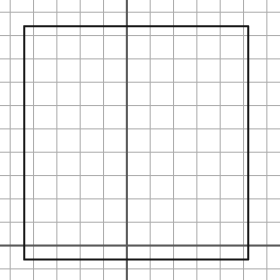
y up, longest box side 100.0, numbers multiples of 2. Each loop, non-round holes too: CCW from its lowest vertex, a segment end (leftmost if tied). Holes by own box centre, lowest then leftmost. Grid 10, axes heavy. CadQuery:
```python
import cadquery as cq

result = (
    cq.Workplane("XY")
    .moveTo(-44.0, -6.0)
    .lineTo(52.0, -6.0)
    .lineTo(52.0, 94.0)
    .lineTo(-44.0, 94.0)
    .close()
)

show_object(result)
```